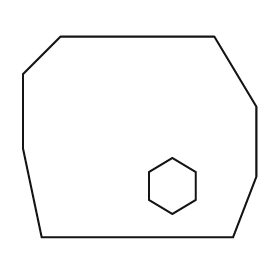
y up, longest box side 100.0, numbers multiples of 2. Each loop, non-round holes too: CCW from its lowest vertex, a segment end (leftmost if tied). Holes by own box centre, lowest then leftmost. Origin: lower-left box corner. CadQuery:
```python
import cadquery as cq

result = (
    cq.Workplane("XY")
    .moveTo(8.0, 0.0)
    .lineTo(90.0, 0.0)
    .lineTo(100.0, 26.0)
    .lineTo(100.0, 56.0)
    .lineTo(82.0, 86.0)
    .lineTo(16.0, 86.0)
    .lineTo(0.0, 70.0)
    .lineTo(0.0, 38.0)
    .close()
    .moveTo(64.0, 10.0)
    .lineTo(74.0, 16.0)
    .lineTo(74.0, 28.0)
    .lineTo(64.0, 34.0)
    .lineTo(54.0, 28.0)
    .lineTo(54.0, 16.0)
    .close()
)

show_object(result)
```